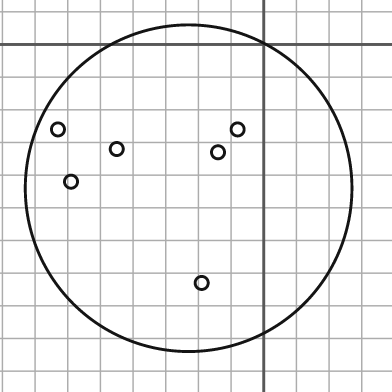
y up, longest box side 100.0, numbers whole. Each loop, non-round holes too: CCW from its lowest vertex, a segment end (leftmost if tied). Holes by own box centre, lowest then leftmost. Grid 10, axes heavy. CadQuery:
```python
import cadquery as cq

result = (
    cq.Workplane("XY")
    .moveTo(-23.0, -44.0)
    .circle(50.0)
    .moveTo(-19.0, -73.0)
    .circle(2.0)
    .moveTo(-59.0, -42.0)
    .circle(2.0)
    .moveTo(-14.0, -33.0)
    .circle(2.0)
    .moveTo(-45.0, -32.0)
    .circle(2.0)
    .moveTo(-63.0, -26.0)
    .circle(2.0)
    .moveTo(-8.0, -26.0)
    .circle(2.0)
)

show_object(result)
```